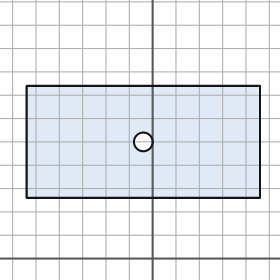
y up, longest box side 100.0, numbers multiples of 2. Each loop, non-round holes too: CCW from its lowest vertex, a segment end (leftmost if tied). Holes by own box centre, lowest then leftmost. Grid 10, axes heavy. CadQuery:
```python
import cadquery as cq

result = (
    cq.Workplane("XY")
    .moveTo(-54.0, 26.0)
    .lineTo(46.0, 26.0)
    .lineTo(46.0, 74.0)
    .lineTo(-54.0, 74.0)
    .close()
    .moveTo(-4.0, 50.0)
    .circle(4.0)
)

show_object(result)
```